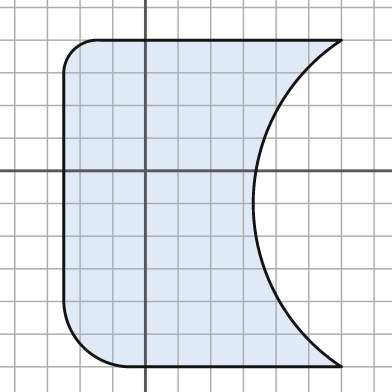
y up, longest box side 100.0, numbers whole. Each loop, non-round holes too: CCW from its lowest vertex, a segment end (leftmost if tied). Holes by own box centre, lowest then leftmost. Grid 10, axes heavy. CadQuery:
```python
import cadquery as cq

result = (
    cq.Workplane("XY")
    .moveTo(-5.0, -60.0)
    .lineTo(60.0, -60.0)
    .threePointArc((33.0, -10.0), (60.0, 40.0))
    .lineTo(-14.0, 40.0)
    .threePointArc((-22.0, 37.0), (-25.0, 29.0))
    .lineTo(-25.0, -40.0)
    .threePointArc((-19.0, -54.0), (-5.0, -60.0))
    .close()
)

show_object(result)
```